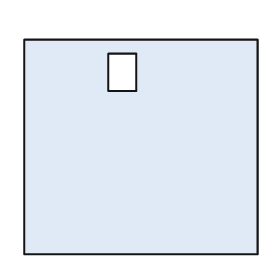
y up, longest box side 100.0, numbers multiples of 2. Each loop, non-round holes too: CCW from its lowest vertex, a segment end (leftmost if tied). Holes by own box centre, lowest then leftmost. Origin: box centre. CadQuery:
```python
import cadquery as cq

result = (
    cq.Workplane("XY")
    .moveTo(-50.0, -46.0)
    .lineTo(50.0, -46.0)
    .lineTo(50.0, 46.0)
    .lineTo(-50.0, 46.0)
    .close()
    .moveTo(-14.0, 24.0)
    .lineTo(-2.0, 24.0)
    .lineTo(-2.0, 40.0)
    .lineTo(-14.0, 40.0)
    .close()
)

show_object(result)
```